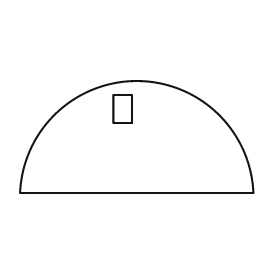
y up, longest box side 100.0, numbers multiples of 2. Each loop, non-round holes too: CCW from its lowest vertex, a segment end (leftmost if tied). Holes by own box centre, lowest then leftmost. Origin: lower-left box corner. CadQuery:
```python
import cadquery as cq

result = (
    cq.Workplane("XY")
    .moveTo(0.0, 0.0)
    .lineTo(100.0, 0.0)
    .threePointArc((50.0, 48.0), (0.0, 0.0))
    .close()
    .moveTo(40.0, 30.0)
    .lineTo(48.0, 30.0)
    .lineTo(48.0, 42.0)
    .lineTo(40.0, 42.0)
    .close()
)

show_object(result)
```